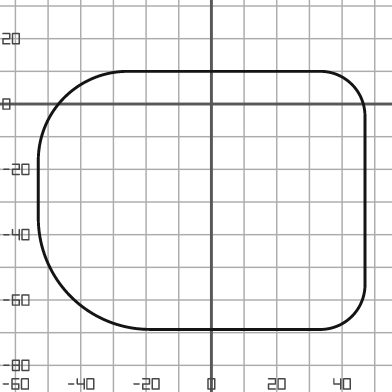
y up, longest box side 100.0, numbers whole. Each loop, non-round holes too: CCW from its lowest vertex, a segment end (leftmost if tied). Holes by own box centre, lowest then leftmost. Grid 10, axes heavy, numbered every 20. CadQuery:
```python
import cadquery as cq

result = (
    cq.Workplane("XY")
    .moveTo(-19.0, -69.0)
    .lineTo(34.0, -69.0)
    .threePointArc((43.0, -65.0), (47.0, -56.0))
    .lineTo(47.0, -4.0)
    .threePointArc((43.0, 6.0), (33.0, 10.0))
    .lineTo(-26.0, 10.0)
    .threePointArc((-45.0, 2.0), (-53.0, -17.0))
    .lineTo(-53.0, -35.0)
    .threePointArc((-43.0, -59.0), (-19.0, -69.0))
    .close()
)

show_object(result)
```